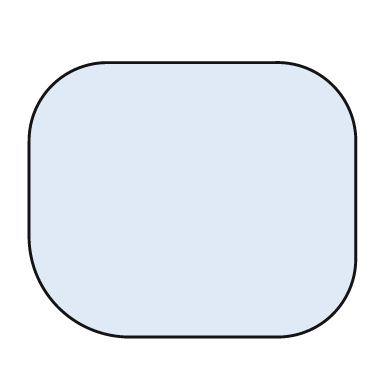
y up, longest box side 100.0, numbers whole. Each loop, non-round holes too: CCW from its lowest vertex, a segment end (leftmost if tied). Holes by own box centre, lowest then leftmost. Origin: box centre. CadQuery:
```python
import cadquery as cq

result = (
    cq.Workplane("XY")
    .moveTo(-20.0, -42.0)
    .lineTo(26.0, -42.0)
    .threePointArc((43.0, -35.0), (50.0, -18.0))
    .lineTo(50.0, 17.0)
    .threePointArc((43.0, 35.0), (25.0, 42.0))
    .lineTo(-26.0, 42.0)
    .threePointArc((-43.0, 35.0), (-50.0, 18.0))
    .lineTo(-50.0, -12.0)
    .threePointArc((-41.0, -33.0), (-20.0, -42.0))
    .close()
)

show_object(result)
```